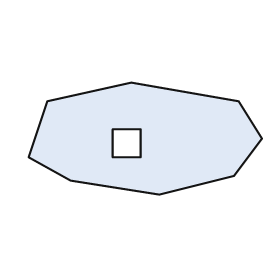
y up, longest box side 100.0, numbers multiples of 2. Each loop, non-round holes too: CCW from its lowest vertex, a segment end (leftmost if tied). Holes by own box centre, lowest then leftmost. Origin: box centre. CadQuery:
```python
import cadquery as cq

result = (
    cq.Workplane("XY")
    .moveTo(6.0, -24.0)
    .lineTo(38.0, -16.0)
    .lineTo(50.0, 0.0)
    .lineTo(40.0, 16.0)
    .lineTo(-6.0, 24.0)
    .lineTo(-42.0, 16.0)
    .lineTo(-50.0, -8.0)
    .lineTo(-32.0, -18.0)
    .close()
    .moveTo(-14.0, -8.0)
    .lineTo(-2.0, -8.0)
    .lineTo(-2.0, 4.0)
    .lineTo(-14.0, 4.0)
    .close()
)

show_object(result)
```